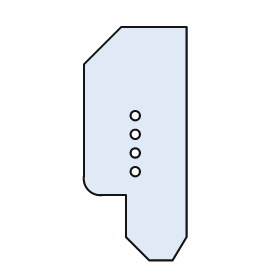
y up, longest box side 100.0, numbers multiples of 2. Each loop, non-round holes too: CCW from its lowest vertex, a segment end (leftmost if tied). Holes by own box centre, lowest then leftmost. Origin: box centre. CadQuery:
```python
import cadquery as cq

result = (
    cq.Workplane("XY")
    .moveTo(6.0, -50.0)
    .lineTo(16.0, -50.0)
    .lineTo(22.0, -40.0)
    .lineTo(22.0, 50.0)
    .lineTo(-6.0, 50.0)
    .lineTo(-22.0, 34.0)
    .lineTo(-22.0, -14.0)
    .threePointArc((-20.0, -20.0), (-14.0, -22.0))
    .lineTo(-4.0, -22.0)
    .lineTo(-4.0, -40.0)
    .close()
    .moveTo(0.0, -12.0)
    .circle(2.0)
    .moveTo(0.0, -4.0)
    .circle(2.0)
    .moveTo(0.0, 4.0)
    .circle(2.0)
    .moveTo(0.0, 12.0)
    .circle(2.0)
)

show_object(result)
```